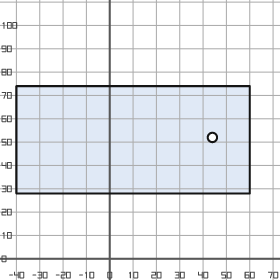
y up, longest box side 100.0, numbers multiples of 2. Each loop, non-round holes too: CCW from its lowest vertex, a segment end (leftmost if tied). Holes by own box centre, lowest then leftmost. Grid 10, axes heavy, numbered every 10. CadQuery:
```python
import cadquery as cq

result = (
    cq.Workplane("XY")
    .moveTo(-40.0, 28.0)
    .lineTo(60.0, 28.0)
    .lineTo(60.0, 74.0)
    .lineTo(-40.0, 74.0)
    .close()
    .moveTo(44.0, 52.0)
    .circle(2.0)
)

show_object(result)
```